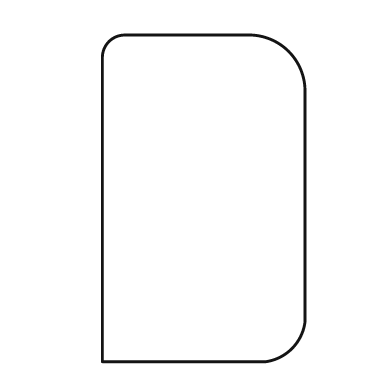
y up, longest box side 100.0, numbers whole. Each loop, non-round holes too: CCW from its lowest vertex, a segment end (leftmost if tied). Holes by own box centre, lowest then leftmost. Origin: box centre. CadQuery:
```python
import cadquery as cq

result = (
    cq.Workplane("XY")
    .moveTo(-31.0, -50.0)
    .lineTo(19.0, -50.0)
    .threePointArc((27.0, -46.0), (31.0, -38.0))
    .lineTo(31.0, 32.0)
    .threePointArc((26.0, 45.0), (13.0, 50.0))
    .lineTo(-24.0, 50.0)
    .threePointArc((-29.0, 48.0), (-31.0, 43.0))
    .close()
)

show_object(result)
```